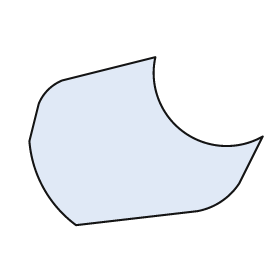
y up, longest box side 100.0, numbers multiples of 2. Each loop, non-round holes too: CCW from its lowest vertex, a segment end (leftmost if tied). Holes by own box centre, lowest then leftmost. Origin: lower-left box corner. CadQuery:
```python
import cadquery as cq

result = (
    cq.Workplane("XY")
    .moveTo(20.0, 0.0)
    .lineTo(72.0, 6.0)
    .threePointArc((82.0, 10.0), (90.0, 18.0))
    .lineTo(100.0, 38.0)
    .threePointArc((66.0, 40.0), (54.0, 72.0))
    .lineTo(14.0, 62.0)
    .threePointArc((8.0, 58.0), (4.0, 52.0))
    .lineTo(0.0, 36.0)
    .threePointArc((6.0, 16.0), (20.0, 0.0))
    .close()
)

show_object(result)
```